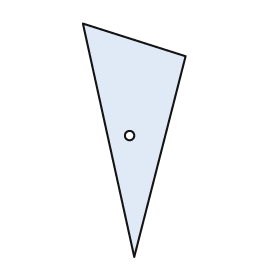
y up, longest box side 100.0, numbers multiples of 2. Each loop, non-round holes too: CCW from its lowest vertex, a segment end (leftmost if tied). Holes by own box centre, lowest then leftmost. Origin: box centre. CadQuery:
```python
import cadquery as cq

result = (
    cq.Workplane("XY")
    .moveTo(0.0, -50.0)
    .lineTo(22.0, 36.0)
    .lineTo(-22.0, 50.0)
    .close()
    .moveTo(-2.0, 2.0)
    .circle(2.0)
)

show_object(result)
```